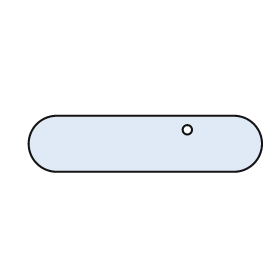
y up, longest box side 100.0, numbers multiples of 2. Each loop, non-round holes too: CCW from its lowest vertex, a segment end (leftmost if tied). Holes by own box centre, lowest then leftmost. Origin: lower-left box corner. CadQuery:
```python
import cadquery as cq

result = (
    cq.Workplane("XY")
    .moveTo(12.0, 0.0)
    .lineTo(88.0, 0.0)
    .threePointArc((100.0, 12.0), (88.0, 24.0))
    .lineTo(12.0, 24.0)
    .threePointArc((0.0, 12.0), (12.0, 0.0))
    .close()
    .moveTo(68.0, 18.0)
    .circle(2.0)
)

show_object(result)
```